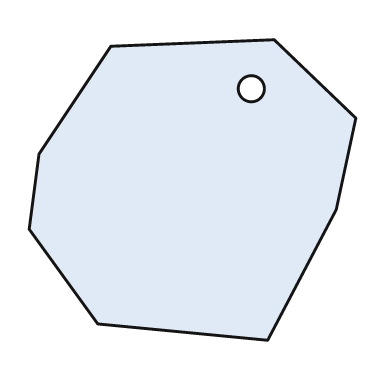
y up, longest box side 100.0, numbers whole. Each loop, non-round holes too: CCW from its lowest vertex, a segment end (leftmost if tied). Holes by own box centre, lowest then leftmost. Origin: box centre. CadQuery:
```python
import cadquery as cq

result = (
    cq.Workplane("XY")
    .moveTo(23.0, -46.0)
    .lineTo(44.0, -6.0)
    .lineTo(50.0, 22.0)
    .lineTo(25.0, 46.0)
    .lineTo(-25.0, 44.0)
    .lineTo(-47.0, 11.0)
    .lineTo(-50.0, -12.0)
    .lineTo(-29.0, -41.0)
    .close()
    .moveTo(18.0, 31.0)
    .circle(4.0)
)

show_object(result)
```